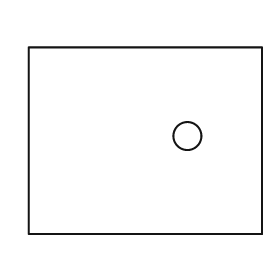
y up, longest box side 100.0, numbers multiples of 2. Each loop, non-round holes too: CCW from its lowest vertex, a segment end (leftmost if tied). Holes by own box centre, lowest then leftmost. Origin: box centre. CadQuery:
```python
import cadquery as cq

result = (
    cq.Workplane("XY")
    .moveTo(-50.0, -40.0)
    .lineTo(50.0, -40.0)
    .lineTo(50.0, 40.0)
    .lineTo(-50.0, 40.0)
    .close()
    .moveTo(18.0, 2.0)
    .circle(6.0)
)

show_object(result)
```